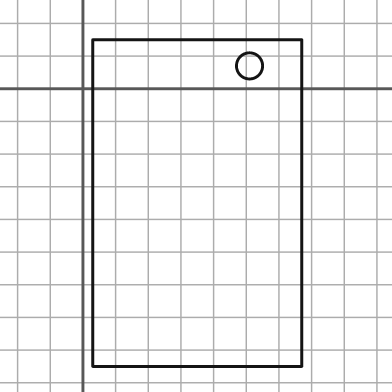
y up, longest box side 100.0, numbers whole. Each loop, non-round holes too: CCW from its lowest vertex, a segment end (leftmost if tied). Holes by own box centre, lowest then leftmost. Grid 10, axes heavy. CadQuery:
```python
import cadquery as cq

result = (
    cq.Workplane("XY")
    .moveTo(3.0, -85.0)
    .lineTo(67.0, -85.0)
    .lineTo(67.0, 15.0)
    .lineTo(3.0, 15.0)
    .close()
    .moveTo(51.0, 7.0)
    .circle(4.0)
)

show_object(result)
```